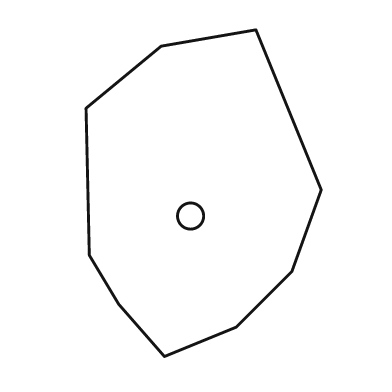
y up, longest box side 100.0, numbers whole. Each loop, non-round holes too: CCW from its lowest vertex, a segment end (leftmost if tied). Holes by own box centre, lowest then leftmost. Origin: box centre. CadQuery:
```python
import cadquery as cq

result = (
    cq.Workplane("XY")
    .moveTo(-12.0, -50.0)
    .lineTo(10.0, -41.0)
    .lineTo(27.0, -24.0)
    .lineTo(36.0, 1.0)
    .lineTo(16.0, 50.0)
    .lineTo(-13.0, 45.0)
    .lineTo(-36.0, 26.0)
    .lineTo(-35.0, -19.0)
    .lineTo(-26.0, -34.0)
    .close()
    .moveTo(-4.0, -7.0)
    .circle(4.0)
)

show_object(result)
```